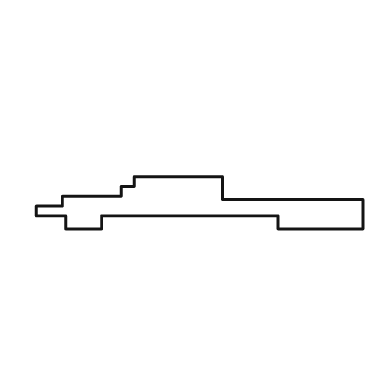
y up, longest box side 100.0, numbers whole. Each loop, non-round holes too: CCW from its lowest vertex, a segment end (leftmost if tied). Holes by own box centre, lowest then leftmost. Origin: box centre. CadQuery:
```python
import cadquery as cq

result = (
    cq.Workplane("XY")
    .moveTo(-41.0, -8.0)
    .lineTo(-30.0, -8.0)
    .lineTo(-30.0, -4.0)
    .lineTo(24.0, -4.0)
    .lineTo(24.0, -8.0)
    .lineTo(50.0, -8.0)
    .lineTo(50.0, 1.0)
    .lineTo(7.0, 1.0)
    .lineTo(7.0, 8.0)
    .lineTo(-20.0, 8.0)
    .lineTo(-20.0, 5.0)
    .lineTo(-24.0, 5.0)
    .lineTo(-24.0, 2.0)
    .lineTo(-42.0, 2.0)
    .lineTo(-42.0, -1.0)
    .lineTo(-50.0, -1.0)
    .lineTo(-50.0, -4.0)
    .lineTo(-41.0, -4.0)
    .close()
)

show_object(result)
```